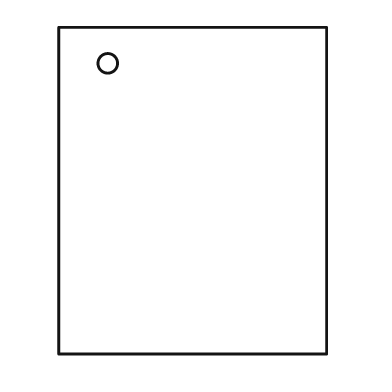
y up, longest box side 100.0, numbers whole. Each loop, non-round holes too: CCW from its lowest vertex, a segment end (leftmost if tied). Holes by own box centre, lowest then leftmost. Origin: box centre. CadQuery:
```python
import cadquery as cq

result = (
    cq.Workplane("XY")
    .moveTo(-41.0, -50.0)
    .lineTo(41.0, -50.0)
    .lineTo(41.0, 50.0)
    .lineTo(-41.0, 50.0)
    .close()
    .moveTo(-26.0, 39.0)
    .circle(3.0)
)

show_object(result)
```